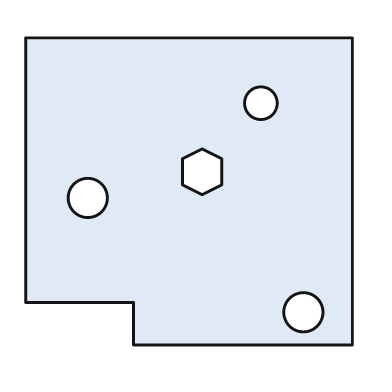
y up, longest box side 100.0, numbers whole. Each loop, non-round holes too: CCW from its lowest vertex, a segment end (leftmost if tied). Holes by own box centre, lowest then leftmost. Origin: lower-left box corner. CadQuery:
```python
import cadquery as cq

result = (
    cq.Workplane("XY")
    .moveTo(33.0, 0.0)
    .lineTo(100.0, 0.0)
    .lineTo(100.0, 94.0)
    .lineTo(0.0, 94.0)
    .lineTo(0.0, 13.0)
    .lineTo(33.0, 13.0)
    .close()
    .moveTo(85.0, 10.0)
    .circle(6.0)
    .moveTo(19.0, 45.0)
    .circle(6.0)
    .moveTo(54.0, 46.0)
    .lineTo(60.0, 49.0)
    .lineTo(60.0, 57.0)
    .lineTo(54.0, 60.0)
    .lineTo(48.0, 57.0)
    .lineTo(48.0, 49.0)
    .close()
    .moveTo(72.0, 74.0)
    .circle(5.0)
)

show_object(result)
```